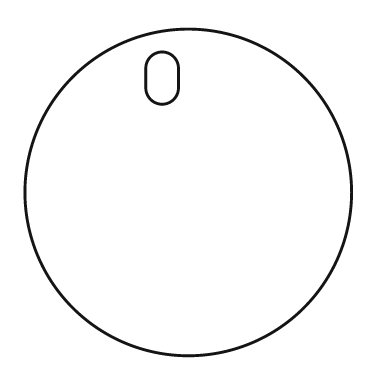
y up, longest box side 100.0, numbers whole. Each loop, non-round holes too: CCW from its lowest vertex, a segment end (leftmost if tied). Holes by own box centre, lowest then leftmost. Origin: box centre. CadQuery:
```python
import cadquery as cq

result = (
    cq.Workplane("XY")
    .moveTo(0.0, 0.0)
    .circle(50.0)
    .moveTo(-13.0, 32.0)
    .threePointArc((-8.0, 27.0), (-3.0, 32.0))
    .lineTo(-3.0, 38.0)
    .threePointArc((-8.0, 43.0), (-13.0, 38.0))
    .close()
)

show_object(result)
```